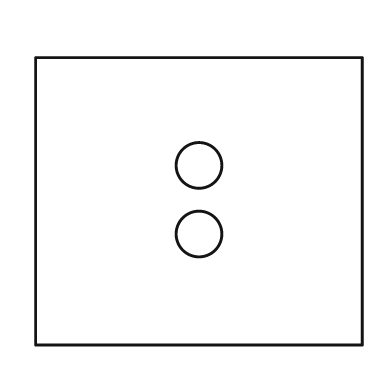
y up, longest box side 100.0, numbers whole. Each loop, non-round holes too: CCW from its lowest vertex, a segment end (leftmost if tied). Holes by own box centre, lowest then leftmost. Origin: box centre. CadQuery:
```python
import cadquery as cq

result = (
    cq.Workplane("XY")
    .moveTo(-50.0, -44.0)
    .lineTo(50.0, -44.0)
    .lineTo(50.0, 44.0)
    .lineTo(-50.0, 44.0)
    .close()
    .moveTo(0.0, -10.0)
    .circle(7.0)
    .moveTo(0.0, 11.0)
    .circle(7.0)
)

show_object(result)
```